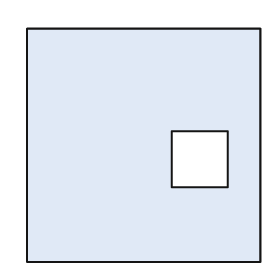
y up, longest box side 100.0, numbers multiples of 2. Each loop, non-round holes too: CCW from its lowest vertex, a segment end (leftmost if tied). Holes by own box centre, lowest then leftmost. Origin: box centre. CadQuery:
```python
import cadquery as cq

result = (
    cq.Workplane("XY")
    .moveTo(-50.0, -50.0)
    .lineTo(50.0, -50.0)
    .lineTo(50.0, 50.0)
    .lineTo(-50.0, 50.0)
    .close()
    .moveTo(12.0, -18.0)
    .lineTo(36.0, -18.0)
    .lineTo(36.0, 6.0)
    .lineTo(12.0, 6.0)
    .close()
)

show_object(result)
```